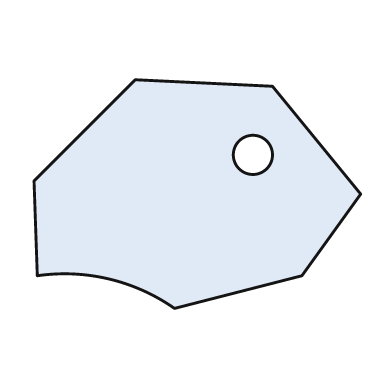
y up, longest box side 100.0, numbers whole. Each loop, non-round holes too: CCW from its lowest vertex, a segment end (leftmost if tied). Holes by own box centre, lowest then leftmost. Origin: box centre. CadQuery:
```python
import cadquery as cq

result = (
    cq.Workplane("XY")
    .moveTo(-7.0, -35.0)
    .lineTo(32.0, -25.0)
    .lineTo(50.0, 0.0)
    .lineTo(23.0, 33.0)
    .lineTo(-19.0, 35.0)
    .lineTo(-50.0, 4.0)
    .lineTo(-49.0, -25.0)
    .threePointArc((-27.0, -26.0), (-7.0, -35.0))
    .close()
    .moveTo(17.0, 12.0)
    .circle(6.0)
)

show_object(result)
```